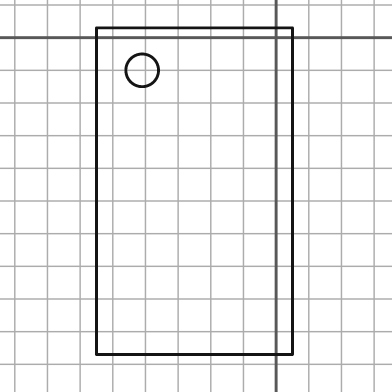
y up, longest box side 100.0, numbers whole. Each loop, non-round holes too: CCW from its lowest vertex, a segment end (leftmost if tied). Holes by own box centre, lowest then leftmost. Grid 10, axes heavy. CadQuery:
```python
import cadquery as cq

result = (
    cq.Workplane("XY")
    .moveTo(-55.0, -97.0)
    .lineTo(5.0, -97.0)
    .lineTo(5.0, 3.0)
    .lineTo(-55.0, 3.0)
    .close()
    .moveTo(-41.0, -10.0)
    .circle(5.0)
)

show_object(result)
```